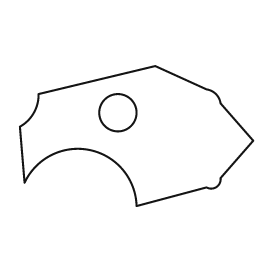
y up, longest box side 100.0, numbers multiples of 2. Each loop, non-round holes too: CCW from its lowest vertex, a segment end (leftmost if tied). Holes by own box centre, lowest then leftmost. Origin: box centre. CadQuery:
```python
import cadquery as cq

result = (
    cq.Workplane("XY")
    .moveTo(0.0, -30.0)
    .lineTo(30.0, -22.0)
    .threePointArc((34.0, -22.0), (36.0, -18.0))
    .lineTo(50.0, -2.0)
    .lineTo(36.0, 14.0)
    .threePointArc((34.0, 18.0), (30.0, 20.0))
    .lineTo(8.0, 30.0)
    .lineTo(-42.0, 18.0)
    .threePointArc((-44.0, 10.0), (-50.0, 4.0))
    .lineTo(-48.0, -20.0)
    .threePointArc((-20.0, -6.0), (0.0, -30.0))
    .close()
    .moveTo(-8.0, 10.0)
    .circle(8.0)
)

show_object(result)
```